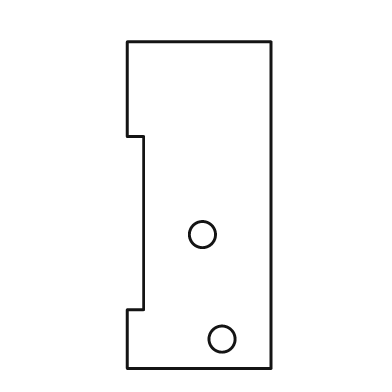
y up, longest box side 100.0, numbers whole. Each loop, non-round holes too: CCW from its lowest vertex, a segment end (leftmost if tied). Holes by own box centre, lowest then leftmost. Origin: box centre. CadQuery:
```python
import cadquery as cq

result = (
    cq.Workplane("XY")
    .moveTo(-22.0, -50.0)
    .lineTo(22.0, -50.0)
    .lineTo(22.0, 50.0)
    .lineTo(-22.0, 50.0)
    .lineTo(-22.0, 21.0)
    .lineTo(-17.0, 21.0)
    .lineTo(-17.0, -32.0)
    .lineTo(-22.0, -32.0)
    .close()
    .moveTo(7.0, -41.0)
    .circle(4.0)
    .moveTo(1.0, -9.0)
    .circle(4.0)
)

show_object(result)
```